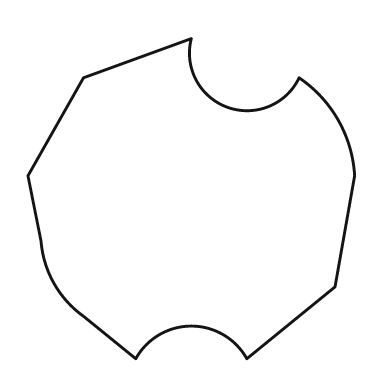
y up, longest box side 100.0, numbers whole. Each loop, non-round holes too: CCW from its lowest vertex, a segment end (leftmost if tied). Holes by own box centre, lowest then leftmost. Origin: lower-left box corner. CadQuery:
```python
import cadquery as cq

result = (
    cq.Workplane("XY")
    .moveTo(33.0, 0.0)
    .threePointArc((50.0, 10.0), (67.0, 0.0))
    .lineTo(94.0, 22.0)
    .lineTo(100.0, 56.0)
    .threePointArc((95.0, 73.0), (83.0, 86.0))
    .threePointArc((61.0, 77.0), (50.0, 98.0))
    .lineTo(17.0, 86.0)
    .lineTo(0.0, 56.0)
    .lineTo(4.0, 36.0)
    .threePointArc((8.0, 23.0), (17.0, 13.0))
    .close()
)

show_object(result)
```